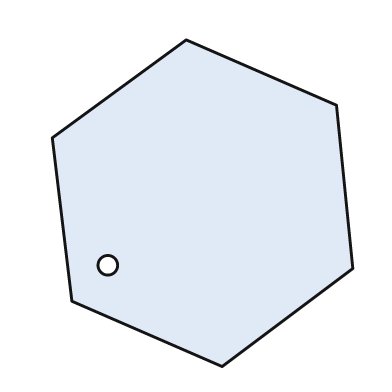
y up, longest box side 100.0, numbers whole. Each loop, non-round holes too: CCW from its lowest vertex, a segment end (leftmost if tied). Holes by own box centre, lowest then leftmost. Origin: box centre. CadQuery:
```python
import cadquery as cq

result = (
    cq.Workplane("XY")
    .moveTo(6.0, -50.0)
    .lineTo(46.0, -20.0)
    .lineTo(41.0, 30.0)
    .lineTo(-5.0, 50.0)
    .lineTo(-46.0, 20.0)
    .lineTo(-40.0, -30.0)
    .close()
    .moveTo(-29.0, -19.0)
    .circle(3.0)
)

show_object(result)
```